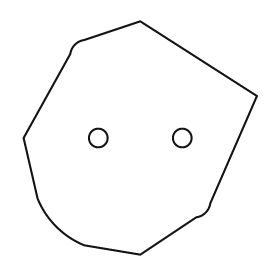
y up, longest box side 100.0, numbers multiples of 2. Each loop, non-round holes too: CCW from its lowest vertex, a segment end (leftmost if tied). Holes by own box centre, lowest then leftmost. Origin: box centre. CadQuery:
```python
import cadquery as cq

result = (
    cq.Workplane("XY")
    .moveTo(0.0, -50.0)
    .lineTo(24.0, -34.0)
    .threePointArc((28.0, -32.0), (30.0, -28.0))
    .lineTo(50.0, 18.0)
    .lineTo(0.0, 50.0)
    .lineTo(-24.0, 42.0)
    .threePointArc((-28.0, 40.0), (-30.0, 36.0))
    .lineTo(-50.0, 0.0)
    .lineTo(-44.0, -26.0)
    .threePointArc((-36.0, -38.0), (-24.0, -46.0))
    .close()
    .moveTo(-18.0, 0.0)
    .circle(4.0)
    .moveTo(18.0, 0.0)
    .circle(4.0)
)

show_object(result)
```